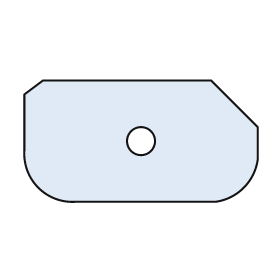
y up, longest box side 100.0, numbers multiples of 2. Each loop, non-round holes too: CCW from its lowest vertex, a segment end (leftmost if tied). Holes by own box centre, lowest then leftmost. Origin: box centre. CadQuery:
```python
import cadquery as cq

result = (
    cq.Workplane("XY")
    .moveTo(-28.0, -26.0)
    .lineTo(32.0, -26.0)
    .threePointArc((44.0, -20.0), (50.0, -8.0))
    .lineTo(50.0, 6.0)
    .lineTo(30.0, 26.0)
    .lineTo(-42.0, 26.0)
    .lineTo(-50.0, 20.0)
    .lineTo(-50.0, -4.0)
    .threePointArc((-44.0, -20.0), (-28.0, -26.0))
    .close()
    .moveTo(0.0, 0.0)
    .circle(6.0)
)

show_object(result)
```